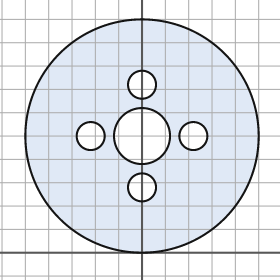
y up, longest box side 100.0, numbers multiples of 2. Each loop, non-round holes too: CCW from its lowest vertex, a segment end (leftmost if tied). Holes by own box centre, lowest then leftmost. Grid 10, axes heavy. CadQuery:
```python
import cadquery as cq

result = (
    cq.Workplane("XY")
    .moveTo(0.0, 50.0)
    .circle(50.0)
    .moveTo(0.0, 28.0)
    .circle(6.0)
    .moveTo(-22.0, 50.0)
    .circle(6.0)
    .moveTo(0.0, 50.0)
    .circle(12.0)
    .moveTo(22.0, 50.0)
    .circle(6.0)
    .moveTo(0.0, 72.0)
    .circle(6.0)
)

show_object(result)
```